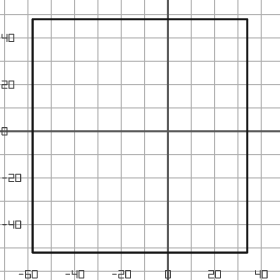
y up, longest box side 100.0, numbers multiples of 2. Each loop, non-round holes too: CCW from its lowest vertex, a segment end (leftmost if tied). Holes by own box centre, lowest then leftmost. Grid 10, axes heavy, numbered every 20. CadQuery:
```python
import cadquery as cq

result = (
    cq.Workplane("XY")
    .moveTo(-58.0, -52.0)
    .lineTo(34.0, -52.0)
    .lineTo(34.0, 48.0)
    .lineTo(-58.0, 48.0)
    .close()
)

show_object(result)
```